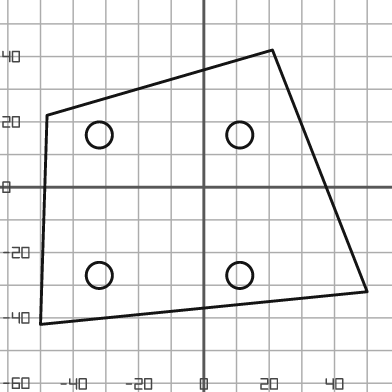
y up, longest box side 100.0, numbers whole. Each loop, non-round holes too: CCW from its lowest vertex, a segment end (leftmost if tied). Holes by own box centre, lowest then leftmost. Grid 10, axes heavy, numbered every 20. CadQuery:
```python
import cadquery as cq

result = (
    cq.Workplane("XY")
    .moveTo(-50.0, -42.0)
    .lineTo(50.0, -32.0)
    .lineTo(21.0, 42.0)
    .lineTo(-48.0, 22.0)
    .close()
    .moveTo(-32.0, -27.0)
    .circle(4.0)
    .moveTo(11.0, -27.0)
    .circle(4.0)
    .moveTo(-32.0, 16.0)
    .circle(4.0)
    .moveTo(11.0, 16.0)
    .circle(4.0)
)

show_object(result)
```